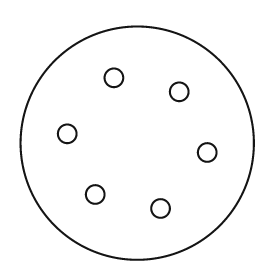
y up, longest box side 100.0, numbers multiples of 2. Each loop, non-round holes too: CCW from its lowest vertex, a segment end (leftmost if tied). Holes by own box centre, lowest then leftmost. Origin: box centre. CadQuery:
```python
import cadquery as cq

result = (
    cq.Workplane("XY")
    .moveTo(0.0, 0.0)
    .circle(50.0)
    .moveTo(10.0, -28.0)
    .circle(4.0)
    .moveTo(-18.0, -22.0)
    .circle(4.0)
    .moveTo(30.0, -4.0)
    .circle(4.0)
    .moveTo(-30.0, 4.0)
    .circle(4.0)
    .moveTo(18.0, 22.0)
    .circle(4.0)
    .moveTo(-10.0, 28.0)
    .circle(4.0)
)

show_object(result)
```